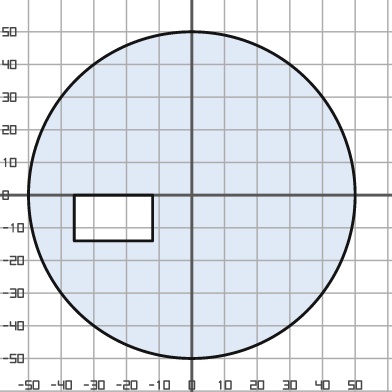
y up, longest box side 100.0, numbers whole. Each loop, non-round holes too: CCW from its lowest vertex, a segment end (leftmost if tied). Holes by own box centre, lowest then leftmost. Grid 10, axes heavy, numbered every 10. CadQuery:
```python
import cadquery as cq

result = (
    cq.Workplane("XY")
    .moveTo(0.0, 0.0)
    .circle(50.0)
    .moveTo(-36.0, -14.0)
    .lineTo(-12.0, -14.0)
    .lineTo(-12.0, 0.0)
    .lineTo(-36.0, 0.0)
    .close()
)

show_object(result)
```